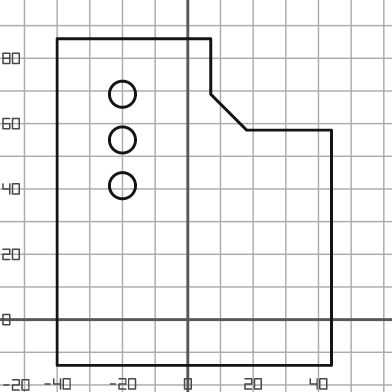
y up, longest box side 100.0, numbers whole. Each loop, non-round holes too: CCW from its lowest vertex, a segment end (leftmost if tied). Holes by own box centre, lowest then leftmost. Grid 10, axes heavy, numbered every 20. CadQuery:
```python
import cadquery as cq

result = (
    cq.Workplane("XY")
    .moveTo(-40.0, -14.0)
    .lineTo(44.0, -14.0)
    .lineTo(44.0, 58.0)
    .lineTo(18.0, 58.0)
    .lineTo(7.0, 69.0)
    .lineTo(7.0, 86.0)
    .lineTo(-40.0, 86.0)
    .close()
    .moveTo(-20.0, 41.0)
    .circle(4.0)
    .moveTo(-20.0, 55.0)
    .circle(4.0)
    .moveTo(-20.0, 69.0)
    .circle(4.0)
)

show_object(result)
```